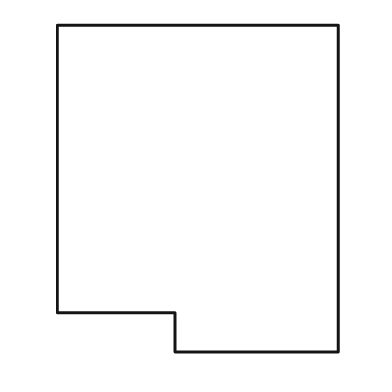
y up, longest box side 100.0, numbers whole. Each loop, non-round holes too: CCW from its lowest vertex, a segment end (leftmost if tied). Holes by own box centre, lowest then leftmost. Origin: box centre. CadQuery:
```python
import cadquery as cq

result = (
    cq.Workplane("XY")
    .moveTo(-7.0, -50.0)
    .lineTo(43.0, -50.0)
    .lineTo(43.0, 50.0)
    .lineTo(-43.0, 50.0)
    .lineTo(-43.0, -38.0)
    .lineTo(-7.0, -38.0)
    .close()
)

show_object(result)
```